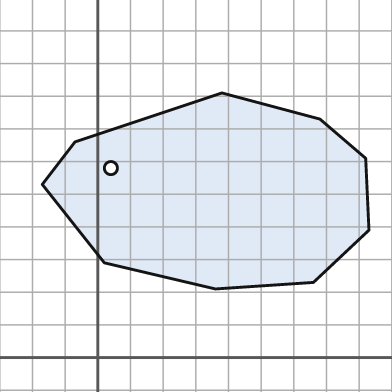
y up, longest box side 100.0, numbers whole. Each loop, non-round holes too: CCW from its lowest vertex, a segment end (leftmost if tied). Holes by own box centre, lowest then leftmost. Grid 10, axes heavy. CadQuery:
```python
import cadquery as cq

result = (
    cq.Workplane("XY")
    .moveTo(36.0, 21.0)
    .lineTo(66.0, 23.0)
    .lineTo(83.0, 39.0)
    .lineTo(82.0, 61.0)
    .lineTo(68.0, 73.0)
    .lineTo(38.0, 81.0)
    .lineTo(-7.0, 66.0)
    .lineTo(-17.0, 53.0)
    .lineTo(2.0, 29.0)
    .close()
    .moveTo(4.0, 58.0)
    .circle(2.0)
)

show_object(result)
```